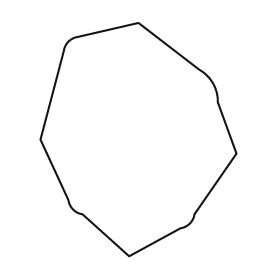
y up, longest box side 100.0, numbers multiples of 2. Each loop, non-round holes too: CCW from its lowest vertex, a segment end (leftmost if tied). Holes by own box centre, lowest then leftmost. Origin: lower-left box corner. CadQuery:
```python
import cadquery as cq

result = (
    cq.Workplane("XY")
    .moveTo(38.0, 0.0)
    .lineTo(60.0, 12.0)
    .threePointArc((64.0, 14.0), (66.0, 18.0))
    .lineTo(84.0, 44.0)
    .lineTo(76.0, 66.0)
    .threePointArc((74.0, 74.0), (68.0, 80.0))
    .lineTo(42.0, 100.0)
    .lineTo(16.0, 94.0)
    .threePointArc((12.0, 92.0), (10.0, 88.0))
    .lineTo(0.0, 50.0)
    .lineTo(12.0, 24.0)
    .threePointArc((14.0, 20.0), (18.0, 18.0))
    .close()
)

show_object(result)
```